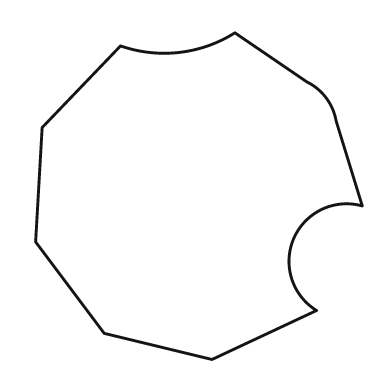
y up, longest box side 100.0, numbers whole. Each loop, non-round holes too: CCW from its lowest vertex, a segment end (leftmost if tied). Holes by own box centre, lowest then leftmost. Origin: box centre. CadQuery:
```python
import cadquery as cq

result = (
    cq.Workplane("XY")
    .moveTo(4.0, -50.0)
    .lineTo(36.0, -35.0)
    .threePointArc((29.0, -13.0), (50.0, -3.0))
    .lineTo(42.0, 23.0)
    .threePointArc((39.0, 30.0), (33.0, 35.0))
    .lineTo(11.0, 50.0)
    .threePointArc((-6.0, 44.0), (-24.0, 46.0))
    .lineTo(-48.0, 21.0)
    .lineTo(-50.0, -14.0)
    .lineTo(-29.0, -42.0)
    .close()
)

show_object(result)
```